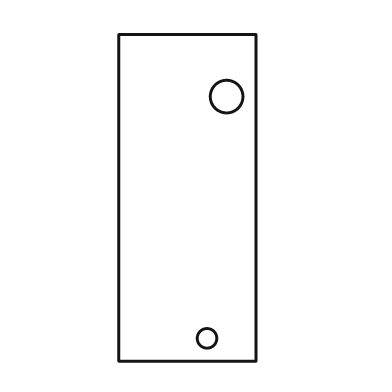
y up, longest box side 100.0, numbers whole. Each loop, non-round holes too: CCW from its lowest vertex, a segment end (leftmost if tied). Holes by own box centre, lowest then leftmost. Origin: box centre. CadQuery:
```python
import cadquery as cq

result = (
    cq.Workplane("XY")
    .moveTo(-21.0, -50.0)
    .lineTo(21.0, -50.0)
    .lineTo(21.0, 50.0)
    .lineTo(-21.0, 50.0)
    .close()
    .moveTo(6.0, -43.0)
    .circle(3.0)
    .moveTo(12.0, 31.0)
    .circle(5.0)
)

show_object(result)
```